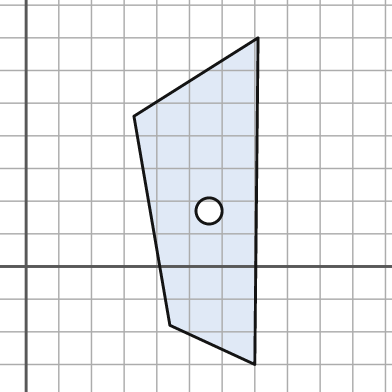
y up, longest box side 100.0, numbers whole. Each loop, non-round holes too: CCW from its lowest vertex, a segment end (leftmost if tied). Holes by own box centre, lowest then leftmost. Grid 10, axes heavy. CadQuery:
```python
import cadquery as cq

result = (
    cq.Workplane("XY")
    .moveTo(70.0, -30.0)
    .lineTo(71.0, 70.0)
    .lineTo(33.0, 46.0)
    .lineTo(44.0, -18.0)
    .close()
    .moveTo(56.0, 17.0)
    .circle(4.0)
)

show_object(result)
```